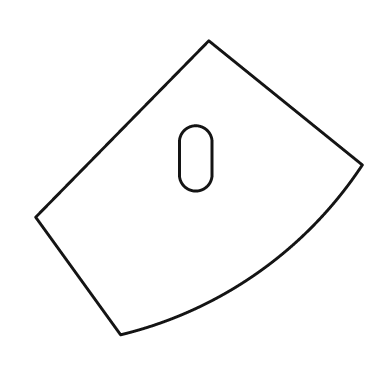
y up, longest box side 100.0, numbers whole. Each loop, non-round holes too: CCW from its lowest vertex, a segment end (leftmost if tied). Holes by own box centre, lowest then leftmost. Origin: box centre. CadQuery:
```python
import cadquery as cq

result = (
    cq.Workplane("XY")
    .moveTo(-24.0, -45.0)
    .threePointArc((18.0, -26.0), (50.0, 7.0))
    .lineTo(3.0, 45.0)
    .lineTo(-50.0, -9.0)
    .close()
    .moveTo(-6.0, 4.0)
    .threePointArc((-1.0, -1.0), (4.0, 4.0))
    .lineTo(4.0, 14.0)
    .threePointArc((-1.0, 19.0), (-6.0, 14.0))
    .close()
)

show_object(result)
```